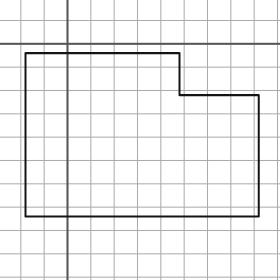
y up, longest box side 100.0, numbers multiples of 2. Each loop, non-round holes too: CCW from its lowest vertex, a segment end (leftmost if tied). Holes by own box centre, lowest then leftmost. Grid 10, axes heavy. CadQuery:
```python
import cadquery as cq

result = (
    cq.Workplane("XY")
    .moveTo(-18.0, -74.0)
    .lineTo(82.0, -74.0)
    .lineTo(82.0, -22.0)
    .lineTo(48.0, -22.0)
    .lineTo(48.0, -4.0)
    .lineTo(-18.0, -4.0)
    .close()
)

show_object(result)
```